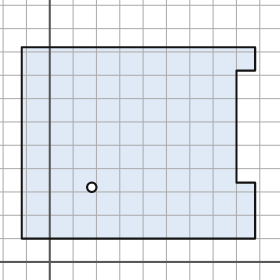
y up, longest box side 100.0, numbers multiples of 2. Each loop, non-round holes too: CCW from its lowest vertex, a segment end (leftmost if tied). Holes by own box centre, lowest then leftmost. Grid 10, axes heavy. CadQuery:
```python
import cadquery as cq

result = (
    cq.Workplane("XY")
    .moveTo(-12.0, 10.0)
    .lineTo(88.0, 10.0)
    .lineTo(88.0, 34.0)
    .lineTo(80.0, 34.0)
    .lineTo(80.0, 82.0)
    .lineTo(88.0, 82.0)
    .lineTo(88.0, 92.0)
    .lineTo(-12.0, 92.0)
    .close()
    .moveTo(18.0, 32.0)
    .circle(2.0)
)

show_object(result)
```